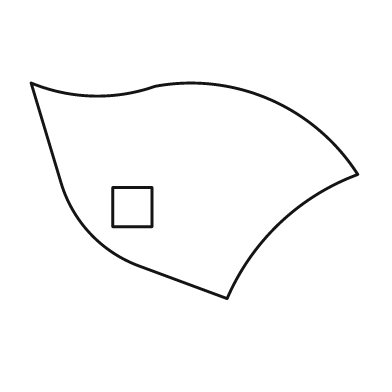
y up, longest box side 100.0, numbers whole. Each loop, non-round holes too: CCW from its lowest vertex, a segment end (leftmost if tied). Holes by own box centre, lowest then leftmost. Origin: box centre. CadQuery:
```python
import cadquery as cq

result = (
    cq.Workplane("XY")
    .moveTo(10.0, -33.0)
    .threePointArc((26.0, -10.0), (50.0, 5.0))
    .threePointArc((23.0, 28.0), (-12.0, 32.0))
    .threePointArc((-31.0, 29.0), (-50.0, 33.0))
    .lineTo(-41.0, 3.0)
    .threePointArc((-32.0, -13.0), (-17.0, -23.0))
    .close()
    .moveTo(-25.0, -11.0)
    .lineTo(-13.0, -11.0)
    .lineTo(-13.0, 1.0)
    .lineTo(-25.0, 1.0)
    .close()
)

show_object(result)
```